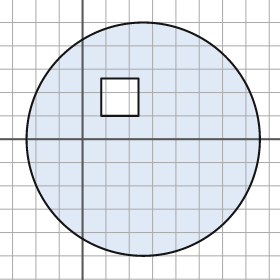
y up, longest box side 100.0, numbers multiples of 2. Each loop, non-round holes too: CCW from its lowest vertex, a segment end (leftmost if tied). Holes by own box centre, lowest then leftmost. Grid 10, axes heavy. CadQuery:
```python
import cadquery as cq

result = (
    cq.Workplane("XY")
    .moveTo(26.0, 0.0)
    .circle(50.0)
    .moveTo(8.0, 10.0)
    .lineTo(24.0, 10.0)
    .lineTo(24.0, 26.0)
    .lineTo(8.0, 26.0)
    .close()
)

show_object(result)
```